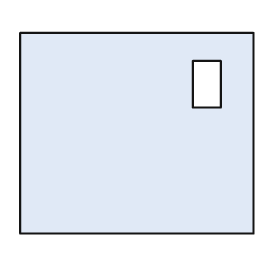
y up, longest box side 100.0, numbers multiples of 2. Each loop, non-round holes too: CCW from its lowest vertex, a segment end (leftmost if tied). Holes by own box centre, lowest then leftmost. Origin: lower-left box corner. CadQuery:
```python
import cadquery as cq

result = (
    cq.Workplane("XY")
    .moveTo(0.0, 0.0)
    .lineTo(100.0, 0.0)
    .lineTo(100.0, 86.0)
    .lineTo(0.0, 86.0)
    .close()
    .moveTo(74.0, 54.0)
    .lineTo(86.0, 54.0)
    .lineTo(86.0, 74.0)
    .lineTo(74.0, 74.0)
    .close()
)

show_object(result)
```